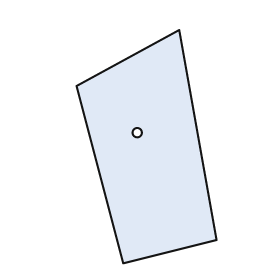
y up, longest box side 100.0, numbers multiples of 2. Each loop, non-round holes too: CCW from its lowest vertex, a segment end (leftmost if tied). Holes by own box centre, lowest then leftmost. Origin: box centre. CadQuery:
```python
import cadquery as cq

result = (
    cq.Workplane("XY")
    .moveTo(-10.0, -50.0)
    .lineTo(30.0, -40.0)
    .lineTo(14.0, 50.0)
    .lineTo(-30.0, 26.0)
    .close()
    .moveTo(-4.0, 6.0)
    .circle(2.0)
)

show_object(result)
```